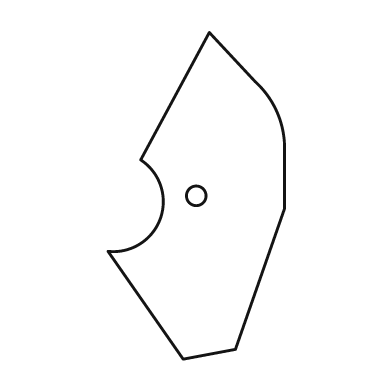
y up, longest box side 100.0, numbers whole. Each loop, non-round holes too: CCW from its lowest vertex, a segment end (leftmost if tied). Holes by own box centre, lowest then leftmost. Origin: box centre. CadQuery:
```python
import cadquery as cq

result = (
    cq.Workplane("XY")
    .moveTo(-4.0, -50.0)
    .lineTo(12.0, -47.0)
    .lineTo(27.0, -4.0)
    .lineTo(27.0, 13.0)
    .threePointArc((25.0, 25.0), (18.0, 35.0))
    .lineTo(4.0, 50.0)
    .lineTo(-17.0, 11.0)
    .threePointArc((-11.0, -7.0), (-27.0, -17.0))
    .close()
    .moveTo(0.0, 0.0)
    .circle(3.0)
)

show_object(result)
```